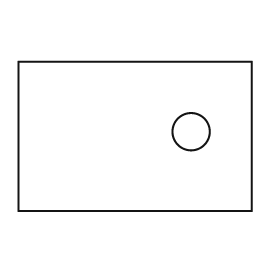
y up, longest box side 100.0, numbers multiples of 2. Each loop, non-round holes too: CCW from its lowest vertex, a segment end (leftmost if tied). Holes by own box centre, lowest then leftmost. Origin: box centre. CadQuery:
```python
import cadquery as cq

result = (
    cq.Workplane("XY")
    .moveTo(-50.0, -32.0)
    .lineTo(50.0, -32.0)
    .lineTo(50.0, 32.0)
    .lineTo(-50.0, 32.0)
    .close()
    .moveTo(24.0, 2.0)
    .circle(8.0)
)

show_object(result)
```